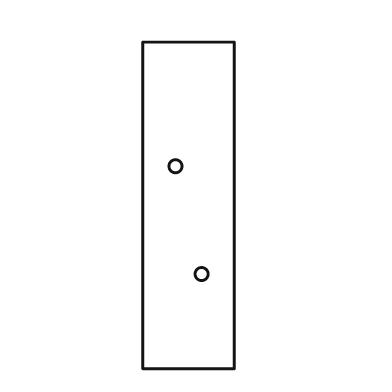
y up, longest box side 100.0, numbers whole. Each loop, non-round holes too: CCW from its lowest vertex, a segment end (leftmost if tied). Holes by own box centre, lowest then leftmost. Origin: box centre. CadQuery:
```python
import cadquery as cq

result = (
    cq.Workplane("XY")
    .moveTo(-14.0, -50.0)
    .lineTo(14.0, -50.0)
    .lineTo(14.0, 50.0)
    .lineTo(-14.0, 50.0)
    .close()
    .moveTo(4.0, -21.0)
    .circle(2.0)
    .moveTo(-4.0, 12.0)
    .circle(2.0)
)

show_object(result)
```